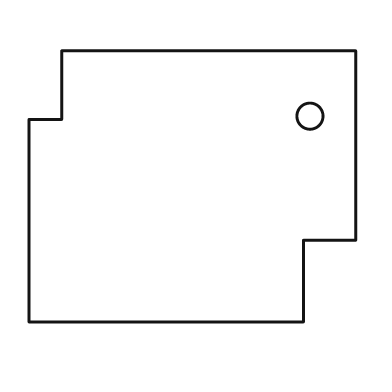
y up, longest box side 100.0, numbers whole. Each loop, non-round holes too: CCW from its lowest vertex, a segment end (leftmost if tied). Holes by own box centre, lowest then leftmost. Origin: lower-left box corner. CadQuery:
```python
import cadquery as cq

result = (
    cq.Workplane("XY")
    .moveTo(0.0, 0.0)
    .lineTo(84.0, 0.0)
    .lineTo(84.0, 25.0)
    .lineTo(100.0, 25.0)
    .lineTo(100.0, 83.0)
    .lineTo(10.0, 83.0)
    .lineTo(10.0, 62.0)
    .lineTo(0.0, 62.0)
    .close()
    .moveTo(86.0, 63.0)
    .circle(4.0)
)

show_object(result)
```